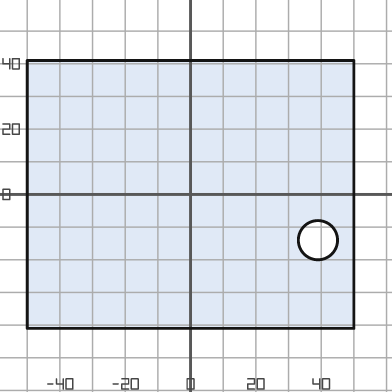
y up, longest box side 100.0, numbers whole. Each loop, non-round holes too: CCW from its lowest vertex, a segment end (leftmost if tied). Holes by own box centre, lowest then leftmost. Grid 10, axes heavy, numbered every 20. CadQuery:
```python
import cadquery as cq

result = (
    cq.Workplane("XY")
    .moveTo(-50.0, -41.0)
    .lineTo(50.0, -41.0)
    .lineTo(50.0, 41.0)
    .lineTo(-50.0, 41.0)
    .close()
    .moveTo(39.0, -14.0)
    .circle(6.0)
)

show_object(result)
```